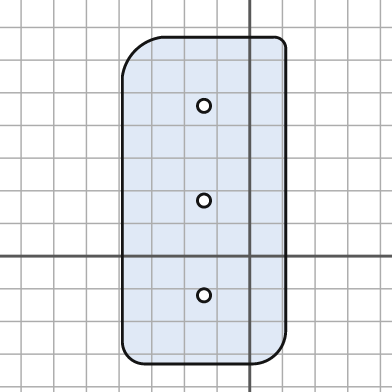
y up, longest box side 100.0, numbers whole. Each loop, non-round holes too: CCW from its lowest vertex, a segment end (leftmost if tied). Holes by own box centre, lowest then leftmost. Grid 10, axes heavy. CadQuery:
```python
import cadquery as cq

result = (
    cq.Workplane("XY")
    .moveTo(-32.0, -33.0)
    .lineTo(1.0, -33.0)
    .threePointArc((8.0, -30.0), (11.0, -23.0))
    .lineTo(11.0, 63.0)
    .threePointArc((10.0, 66.0), (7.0, 67.0))
    .lineTo(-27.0, 67.0)
    .threePointArc((-35.0, 63.0), (-39.0, 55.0))
    .lineTo(-39.0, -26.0)
    .threePointArc((-37.0, -31.0), (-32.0, -33.0))
    .close()
    .moveTo(-14.0, -12.0)
    .circle(2.0)
    .moveTo(-14.0, 17.0)
    .circle(2.0)
    .moveTo(-14.0, 46.0)
    .circle(2.0)
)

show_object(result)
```